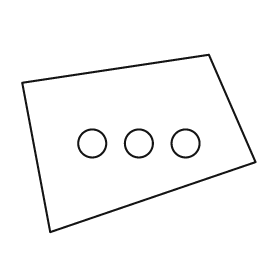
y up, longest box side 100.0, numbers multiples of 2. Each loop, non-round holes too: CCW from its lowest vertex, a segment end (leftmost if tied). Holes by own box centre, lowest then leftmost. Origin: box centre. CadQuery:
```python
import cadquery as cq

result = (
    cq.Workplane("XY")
    .moveTo(-38.0, -38.0)
    .lineTo(50.0, -8.0)
    .lineTo(30.0, 38.0)
    .lineTo(-50.0, 26.0)
    .close()
    .moveTo(-20.0, 0.0)
    .circle(6.0)
    .moveTo(0.0, 0.0)
    .circle(6.0)
    .moveTo(20.0, 0.0)
    .circle(6.0)
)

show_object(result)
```